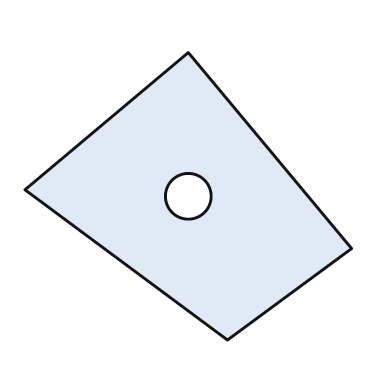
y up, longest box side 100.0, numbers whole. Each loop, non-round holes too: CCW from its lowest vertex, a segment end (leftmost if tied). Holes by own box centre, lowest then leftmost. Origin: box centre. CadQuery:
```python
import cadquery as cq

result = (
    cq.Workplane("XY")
    .moveTo(12.0, -44.0)
    .lineTo(50.0, -16.0)
    .lineTo(0.0, 44.0)
    .lineTo(-50.0, 2.0)
    .close()
    .moveTo(0.0, 0.0)
    .circle(7.0)
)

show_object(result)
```